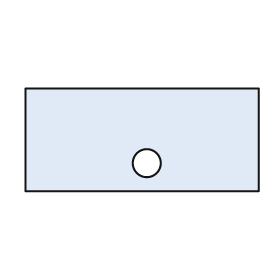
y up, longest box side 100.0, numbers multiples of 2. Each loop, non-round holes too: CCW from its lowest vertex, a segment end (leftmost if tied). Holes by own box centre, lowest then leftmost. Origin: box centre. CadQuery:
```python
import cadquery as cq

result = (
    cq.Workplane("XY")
    .moveTo(-50.0, -22.0)
    .lineTo(50.0, -22.0)
    .lineTo(50.0, 22.0)
    .lineTo(-50.0, 22.0)
    .close()
    .moveTo(2.0, -10.0)
    .circle(6.0)
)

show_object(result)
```